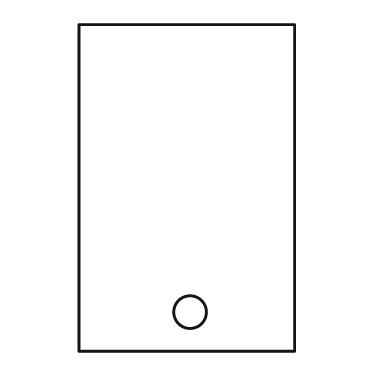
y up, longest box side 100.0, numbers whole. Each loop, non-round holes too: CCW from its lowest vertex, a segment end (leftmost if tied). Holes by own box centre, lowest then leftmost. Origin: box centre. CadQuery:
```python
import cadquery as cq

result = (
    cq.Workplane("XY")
    .moveTo(-33.0, -50.0)
    .lineTo(33.0, -50.0)
    .lineTo(33.0, 50.0)
    .lineTo(-33.0, 50.0)
    .close()
    .moveTo(1.0, -38.0)
    .circle(5.0)
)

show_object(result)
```